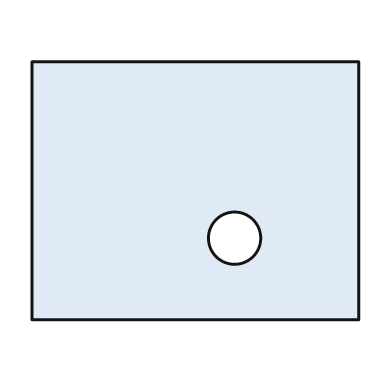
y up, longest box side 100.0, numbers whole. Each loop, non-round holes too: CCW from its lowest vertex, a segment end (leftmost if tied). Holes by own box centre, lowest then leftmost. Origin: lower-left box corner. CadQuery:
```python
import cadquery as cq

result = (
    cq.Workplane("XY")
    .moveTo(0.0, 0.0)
    .lineTo(100.0, 0.0)
    .lineTo(100.0, 79.0)
    .lineTo(0.0, 79.0)
    .close()
    .moveTo(62.0, 25.0)
    .circle(8.0)
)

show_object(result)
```